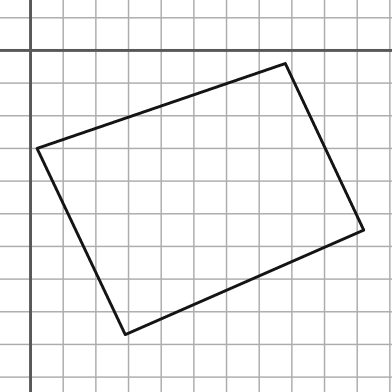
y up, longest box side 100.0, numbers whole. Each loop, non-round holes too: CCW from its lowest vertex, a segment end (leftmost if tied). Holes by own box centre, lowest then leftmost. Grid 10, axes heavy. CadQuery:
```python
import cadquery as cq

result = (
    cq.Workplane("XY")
    .moveTo(29.0, -87.0)
    .lineTo(102.0, -55.0)
    .lineTo(78.0, -4.0)
    .lineTo(2.0, -30.0)
    .close()
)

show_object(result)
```